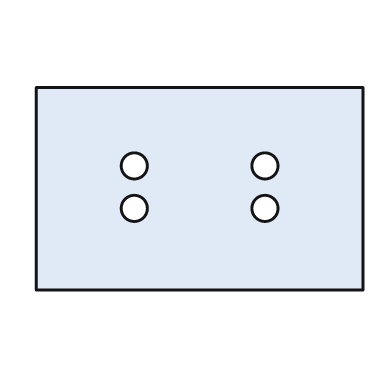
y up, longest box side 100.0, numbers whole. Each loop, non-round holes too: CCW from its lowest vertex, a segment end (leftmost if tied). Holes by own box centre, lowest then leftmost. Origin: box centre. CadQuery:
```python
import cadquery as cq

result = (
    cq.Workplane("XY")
    .moveTo(-50.0, -31.0)
    .lineTo(50.0, -31.0)
    .lineTo(50.0, 31.0)
    .lineTo(-50.0, 31.0)
    .close()
    .moveTo(-20.0, -6.0)
    .circle(4.0)
    .moveTo(20.0, -6.0)
    .circle(4.0)
    .moveTo(-20.0, 7.0)
    .circle(4.0)
    .moveTo(20.0, 7.0)
    .circle(4.0)
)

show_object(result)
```